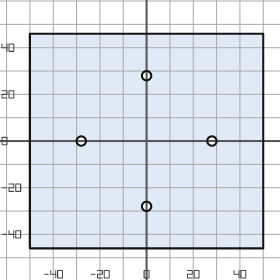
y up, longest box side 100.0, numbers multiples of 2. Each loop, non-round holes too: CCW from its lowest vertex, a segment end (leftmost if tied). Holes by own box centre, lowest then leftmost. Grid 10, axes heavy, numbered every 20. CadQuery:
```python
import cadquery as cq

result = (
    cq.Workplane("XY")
    .moveTo(-50.0, -46.0)
    .lineTo(50.0, -46.0)
    .lineTo(50.0, 46.0)
    .lineTo(-50.0, 46.0)
    .close()
    .moveTo(0.0, -28.0)
    .circle(2.0)
    .moveTo(-28.0, 0.0)
    .circle(2.0)
    .moveTo(28.0, 0.0)
    .circle(2.0)
    .moveTo(0.0, 28.0)
    .circle(2.0)
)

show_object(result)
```